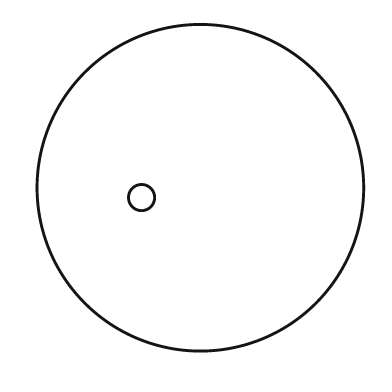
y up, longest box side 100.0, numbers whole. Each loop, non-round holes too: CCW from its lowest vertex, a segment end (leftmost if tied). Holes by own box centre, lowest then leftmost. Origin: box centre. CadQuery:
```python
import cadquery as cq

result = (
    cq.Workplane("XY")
    .moveTo(0.0, 0.0)
    .circle(50.0)
    .moveTo(-18.0, -3.0)
    .circle(4.0)
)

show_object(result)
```